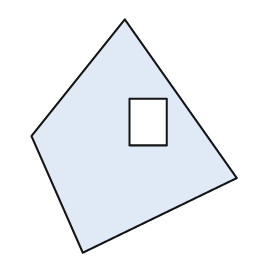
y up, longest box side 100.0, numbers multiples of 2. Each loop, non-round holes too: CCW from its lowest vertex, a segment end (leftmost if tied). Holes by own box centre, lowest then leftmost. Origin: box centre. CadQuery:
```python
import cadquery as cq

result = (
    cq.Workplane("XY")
    .moveTo(-22.0, -50.0)
    .lineTo(44.0, -18.0)
    .lineTo(-4.0, 50.0)
    .lineTo(-44.0, 0.0)
    .close()
    .moveTo(-2.0, -4.0)
    .lineTo(14.0, -4.0)
    .lineTo(14.0, 16.0)
    .lineTo(-2.0, 16.0)
    .close()
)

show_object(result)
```